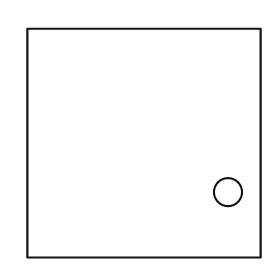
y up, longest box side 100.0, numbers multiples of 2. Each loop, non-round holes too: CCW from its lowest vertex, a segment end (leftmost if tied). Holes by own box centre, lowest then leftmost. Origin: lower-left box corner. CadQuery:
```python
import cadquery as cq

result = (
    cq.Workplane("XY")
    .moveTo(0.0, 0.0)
    .lineTo(100.0, 0.0)
    .lineTo(100.0, 98.0)
    .lineTo(0.0, 98.0)
    .close()
    .moveTo(86.0, 28.0)
    .circle(6.0)
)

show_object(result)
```